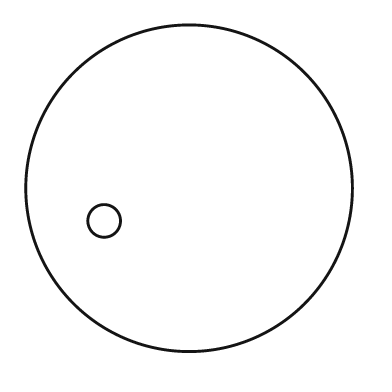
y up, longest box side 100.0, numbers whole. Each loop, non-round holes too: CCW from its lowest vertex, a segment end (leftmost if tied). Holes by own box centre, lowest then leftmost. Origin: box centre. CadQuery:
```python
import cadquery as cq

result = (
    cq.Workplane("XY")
    .moveTo(0.0, 0.0)
    .circle(50.0)
    .moveTo(-26.0, -10.0)
    .circle(5.0)
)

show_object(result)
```